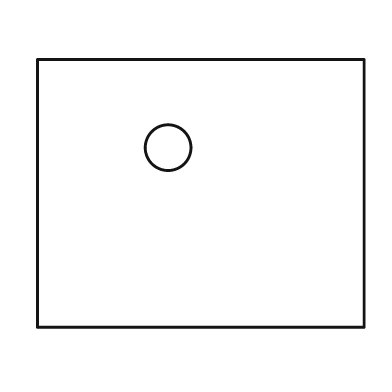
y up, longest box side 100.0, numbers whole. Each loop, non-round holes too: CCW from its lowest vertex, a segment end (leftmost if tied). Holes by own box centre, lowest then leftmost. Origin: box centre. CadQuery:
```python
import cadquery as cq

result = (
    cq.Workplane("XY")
    .moveTo(-50.0, -41.0)
    .lineTo(50.0, -41.0)
    .lineTo(50.0, 41.0)
    .lineTo(-50.0, 41.0)
    .close()
    .moveTo(-10.0, 14.0)
    .circle(7.0)
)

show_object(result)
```